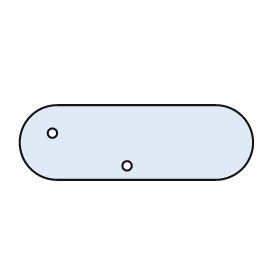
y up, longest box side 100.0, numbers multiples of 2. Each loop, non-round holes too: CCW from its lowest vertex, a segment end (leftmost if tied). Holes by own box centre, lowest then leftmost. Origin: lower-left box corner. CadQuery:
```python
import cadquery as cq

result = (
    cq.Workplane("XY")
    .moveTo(16.0, 0.0)
    .lineTo(84.0, 0.0)
    .threePointArc((100.0, 16.0), (84.0, 32.0))
    .lineTo(16.0, 32.0)
    .threePointArc((0.0, 16.0), (16.0, 0.0))
    .close()
    .moveTo(46.0, 6.0)
    .circle(2.0)
    .moveTo(14.0, 20.0)
    .circle(2.0)
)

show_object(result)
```